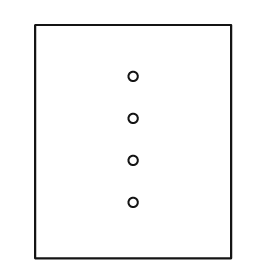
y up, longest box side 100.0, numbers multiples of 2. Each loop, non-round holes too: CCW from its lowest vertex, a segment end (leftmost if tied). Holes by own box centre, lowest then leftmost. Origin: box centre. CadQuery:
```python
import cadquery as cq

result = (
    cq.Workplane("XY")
    .moveTo(-42.0, -50.0)
    .lineTo(42.0, -50.0)
    .lineTo(42.0, 50.0)
    .lineTo(-42.0, 50.0)
    .close()
    .moveTo(0.0, -26.0)
    .circle(2.0)
    .moveTo(0.0, -8.0)
    .circle(2.0)
    .moveTo(0.0, 10.0)
    .circle(2.0)
    .moveTo(0.0, 28.0)
    .circle(2.0)
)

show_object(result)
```